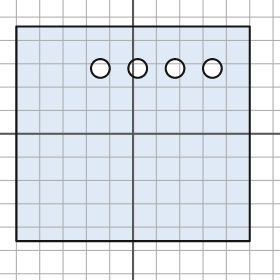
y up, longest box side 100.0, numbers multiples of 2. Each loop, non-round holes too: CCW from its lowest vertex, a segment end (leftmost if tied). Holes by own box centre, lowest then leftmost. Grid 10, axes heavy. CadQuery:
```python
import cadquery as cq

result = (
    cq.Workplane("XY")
    .moveTo(-50.0, -46.0)
    .lineTo(50.0, -46.0)
    .lineTo(50.0, 46.0)
    .lineTo(-50.0, 46.0)
    .close()
    .moveTo(-14.0, 28.0)
    .circle(4.0)
    .moveTo(2.0, 28.0)
    .circle(4.0)
    .moveTo(18.0, 28.0)
    .circle(4.0)
    .moveTo(34.0, 28.0)
    .circle(4.0)
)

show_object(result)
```